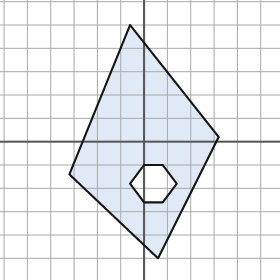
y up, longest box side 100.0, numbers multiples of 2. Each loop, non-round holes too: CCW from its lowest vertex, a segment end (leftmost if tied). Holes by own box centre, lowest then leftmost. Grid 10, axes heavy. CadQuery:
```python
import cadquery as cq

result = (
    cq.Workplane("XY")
    .moveTo(6.0, -50.0)
    .lineTo(32.0, 2.0)
    .lineTo(-6.0, 50.0)
    .lineTo(-32.0, -14.0)
    .close()
    .moveTo(0.0, -26.0)
    .lineTo(8.0, -26.0)
    .lineTo(14.0, -18.0)
    .lineTo(8.0, -10.0)
    .lineTo(0.0, -10.0)
    .lineTo(-6.0, -18.0)
    .close()
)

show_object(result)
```